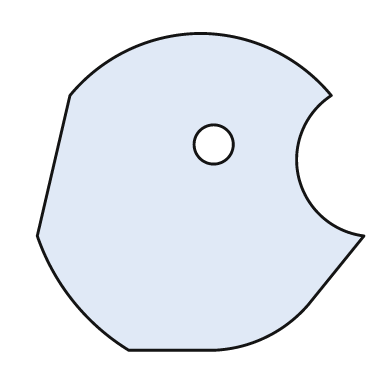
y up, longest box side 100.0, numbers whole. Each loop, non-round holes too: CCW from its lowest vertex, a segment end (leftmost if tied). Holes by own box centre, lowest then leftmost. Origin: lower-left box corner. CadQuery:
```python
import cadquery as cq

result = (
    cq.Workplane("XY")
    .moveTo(28.0, 0.0)
    .lineTo(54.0, 0.0)
    .threePointArc((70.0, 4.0), (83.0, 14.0))
    .lineTo(100.0, 35.0)
    .threePointArc((80.0, 53.0), (90.0, 78.0))
    .threePointArc((72.0, 92.0), (50.0, 97.0))
    .threePointArc((28.0, 92.0), (10.0, 78.0))
    .lineTo(0.0, 35.0)
    .threePointArc((11.0, 15.0), (28.0, 0.0))
    .close()
    .moveTo(54.0, 63.0)
    .circle(6.0)
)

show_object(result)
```